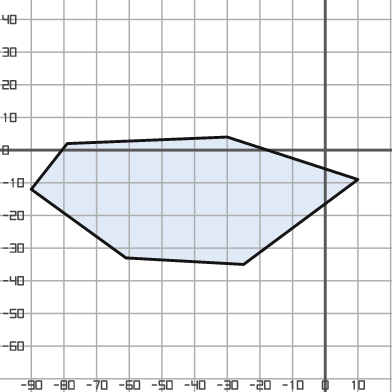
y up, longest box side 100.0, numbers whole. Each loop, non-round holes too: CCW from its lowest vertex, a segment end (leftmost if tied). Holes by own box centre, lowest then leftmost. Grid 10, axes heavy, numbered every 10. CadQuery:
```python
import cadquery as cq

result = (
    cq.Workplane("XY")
    .moveTo(-25.0, -35.0)
    .lineTo(10.0, -9.0)
    .lineTo(-30.0, 4.0)
    .lineTo(-79.0, 2.0)
    .lineTo(-90.0, -12.0)
    .lineTo(-61.0, -33.0)
    .close()
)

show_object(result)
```